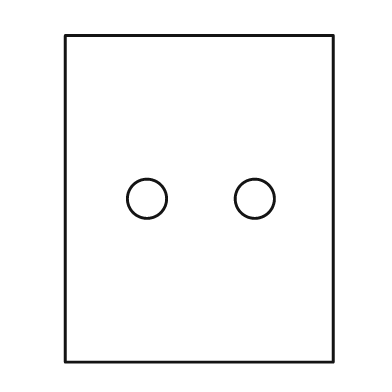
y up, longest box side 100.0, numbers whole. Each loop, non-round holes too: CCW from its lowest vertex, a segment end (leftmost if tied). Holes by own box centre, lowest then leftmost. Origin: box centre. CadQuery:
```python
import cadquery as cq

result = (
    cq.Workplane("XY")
    .moveTo(-41.0, -50.0)
    .lineTo(41.0, -50.0)
    .lineTo(41.0, 50.0)
    .lineTo(-41.0, 50.0)
    .close()
    .moveTo(-16.0, 0.0)
    .circle(6.0)
    .moveTo(17.0, 0.0)
    .circle(6.0)
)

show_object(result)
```